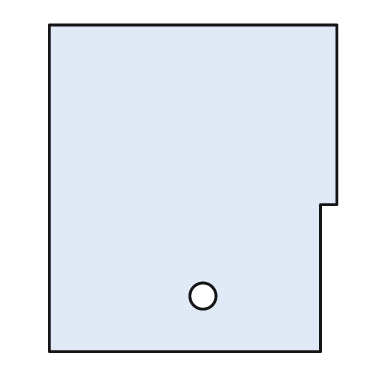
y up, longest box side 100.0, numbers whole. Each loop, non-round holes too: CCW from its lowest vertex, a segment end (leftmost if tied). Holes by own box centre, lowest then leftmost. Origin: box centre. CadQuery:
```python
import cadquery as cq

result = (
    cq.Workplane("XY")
    .moveTo(-44.0, -50.0)
    .lineTo(39.0, -50.0)
    .lineTo(39.0, -5.0)
    .lineTo(44.0, -5.0)
    .lineTo(44.0, 50.0)
    .lineTo(-44.0, 50.0)
    .close()
    .moveTo(3.0, -33.0)
    .circle(4.0)
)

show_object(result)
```